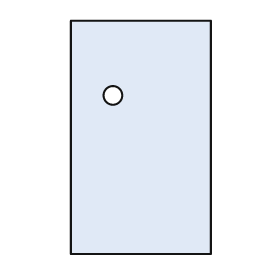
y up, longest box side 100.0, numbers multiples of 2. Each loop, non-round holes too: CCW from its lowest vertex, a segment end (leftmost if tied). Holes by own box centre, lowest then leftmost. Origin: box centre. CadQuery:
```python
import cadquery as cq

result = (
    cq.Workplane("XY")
    .moveTo(-30.0, -50.0)
    .lineTo(30.0, -50.0)
    .lineTo(30.0, 50.0)
    .lineTo(-30.0, 50.0)
    .close()
    .moveTo(-12.0, 18.0)
    .circle(4.0)
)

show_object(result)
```